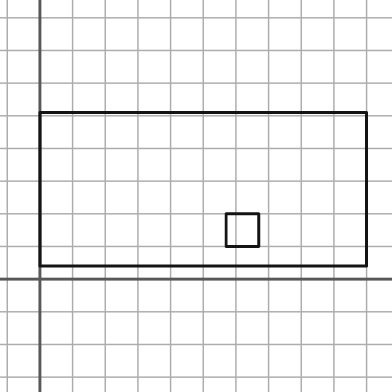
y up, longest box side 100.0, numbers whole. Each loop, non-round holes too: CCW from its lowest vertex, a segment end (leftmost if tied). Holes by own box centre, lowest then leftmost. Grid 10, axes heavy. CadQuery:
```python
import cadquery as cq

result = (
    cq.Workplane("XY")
    .moveTo(0.0, 4.0)
    .lineTo(100.0, 4.0)
    .lineTo(100.0, 51.0)
    .lineTo(0.0, 51.0)
    .close()
    .moveTo(57.0, 10.0)
    .lineTo(67.0, 10.0)
    .lineTo(67.0, 20.0)
    .lineTo(57.0, 20.0)
    .close()
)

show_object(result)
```